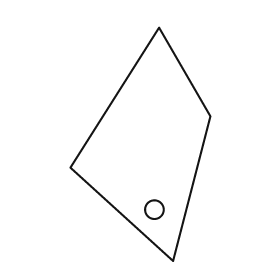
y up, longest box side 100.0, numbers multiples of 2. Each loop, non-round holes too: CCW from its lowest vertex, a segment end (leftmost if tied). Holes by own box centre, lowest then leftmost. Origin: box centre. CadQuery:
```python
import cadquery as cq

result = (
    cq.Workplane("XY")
    .moveTo(14.0, -50.0)
    .lineTo(30.0, 12.0)
    .lineTo(8.0, 50.0)
    .lineTo(-30.0, -10.0)
    .close()
    .moveTo(6.0, -28.0)
    .circle(4.0)
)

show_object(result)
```